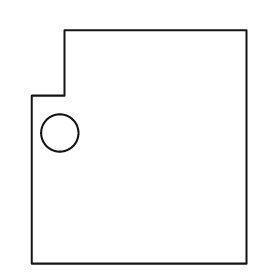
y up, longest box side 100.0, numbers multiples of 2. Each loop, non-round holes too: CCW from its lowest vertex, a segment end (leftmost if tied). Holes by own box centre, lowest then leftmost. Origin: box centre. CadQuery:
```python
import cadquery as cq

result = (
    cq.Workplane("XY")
    .moveTo(-46.0, -50.0)
    .lineTo(46.0, -50.0)
    .lineTo(46.0, 50.0)
    .lineTo(-32.0, 50.0)
    .lineTo(-32.0, 22.0)
    .lineTo(-46.0, 22.0)
    .close()
    .moveTo(-34.0, 6.0)
    .circle(8.0)
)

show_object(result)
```